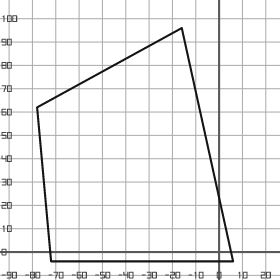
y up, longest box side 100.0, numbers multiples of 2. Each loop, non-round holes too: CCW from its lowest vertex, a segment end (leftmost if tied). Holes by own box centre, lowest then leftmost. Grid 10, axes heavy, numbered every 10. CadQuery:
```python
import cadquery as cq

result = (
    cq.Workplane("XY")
    .moveTo(-72.0, -4.0)
    .lineTo(6.0, -4.0)
    .lineTo(-16.0, 96.0)
    .lineTo(-78.0, 62.0)
    .close()
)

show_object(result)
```